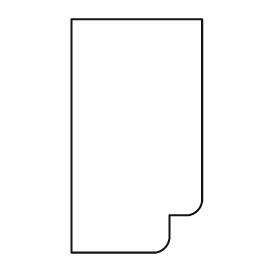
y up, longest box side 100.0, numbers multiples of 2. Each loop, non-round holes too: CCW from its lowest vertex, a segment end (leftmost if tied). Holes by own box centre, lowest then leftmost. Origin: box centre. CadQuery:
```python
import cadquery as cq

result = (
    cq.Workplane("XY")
    .moveTo(-28.0, -50.0)
    .lineTo(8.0, -50.0)
    .threePointArc((12.0, -48.0), (14.0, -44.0))
    .lineTo(14.0, -34.0)
    .lineTo(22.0, -34.0)
    .threePointArc((26.0, -32.0), (28.0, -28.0))
    .lineTo(28.0, 50.0)
    .lineTo(-28.0, 50.0)
    .close()
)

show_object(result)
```